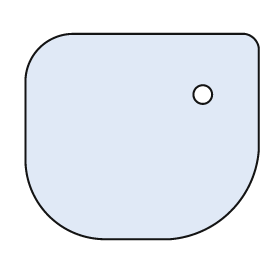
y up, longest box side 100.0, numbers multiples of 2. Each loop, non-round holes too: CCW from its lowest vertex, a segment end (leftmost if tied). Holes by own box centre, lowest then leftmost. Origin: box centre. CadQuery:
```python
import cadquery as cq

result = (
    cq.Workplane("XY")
    .moveTo(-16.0, -44.0)
    .lineTo(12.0, -44.0)
    .threePointArc((38.0, -32.0), (50.0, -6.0))
    .lineTo(50.0, 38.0)
    .threePointArc((48.0, 42.0), (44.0, 44.0))
    .lineTo(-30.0, 44.0)
    .threePointArc((-44.0, 38.0), (-50.0, 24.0))
    .lineTo(-50.0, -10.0)
    .threePointArc((-40.0, -34.0), (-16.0, -44.0))
    .close()
    .moveTo(26.0, 18.0)
    .circle(4.0)
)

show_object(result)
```